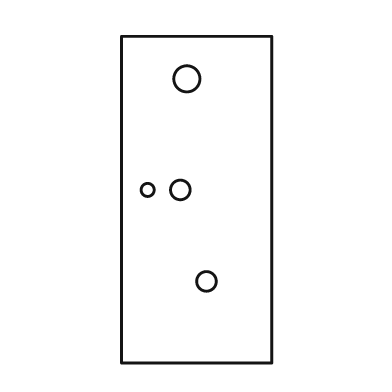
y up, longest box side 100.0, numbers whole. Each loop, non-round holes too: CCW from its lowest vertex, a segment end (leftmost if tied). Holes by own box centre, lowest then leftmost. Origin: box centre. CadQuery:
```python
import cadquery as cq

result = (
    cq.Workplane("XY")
    .moveTo(-23.0, -50.0)
    .lineTo(23.0, -50.0)
    .lineTo(23.0, 50.0)
    .lineTo(-23.0, 50.0)
    .close()
    .moveTo(3.0, -25.0)
    .circle(3.0)
    .moveTo(-15.0, 3.0)
    .circle(2.0)
    .moveTo(-5.0, 3.0)
    .circle(3.0)
    .moveTo(-3.0, 37.0)
    .circle(4.0)
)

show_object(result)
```